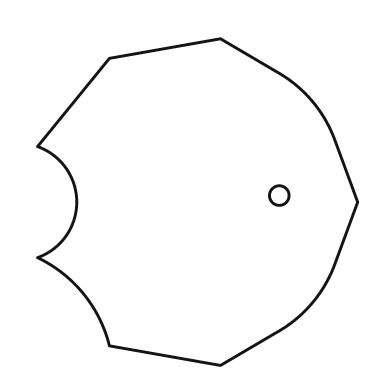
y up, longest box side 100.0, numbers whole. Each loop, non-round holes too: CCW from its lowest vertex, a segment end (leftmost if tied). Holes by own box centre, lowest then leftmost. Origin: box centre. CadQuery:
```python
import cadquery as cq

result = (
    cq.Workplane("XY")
    .moveTo(7.0, -50.0)
    .lineTo(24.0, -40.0)
    .threePointArc((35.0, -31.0), (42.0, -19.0))
    .lineTo(49.0, 0.0)
    .lineTo(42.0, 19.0)
    .threePointArc((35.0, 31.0), (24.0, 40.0))
    .lineTo(7.0, 50.0)
    .lineTo(-27.0, 44.0)
    .lineTo(-49.0, 17.0)
    .threePointArc((-37.0, 0.0), (-49.0, -17.0))
    .threePointArc((-35.0, -28.0), (-27.0, -44.0))
    .close()
    .moveTo(25.0, 2.0)
    .circle(3.0)
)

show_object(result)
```